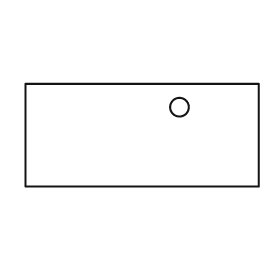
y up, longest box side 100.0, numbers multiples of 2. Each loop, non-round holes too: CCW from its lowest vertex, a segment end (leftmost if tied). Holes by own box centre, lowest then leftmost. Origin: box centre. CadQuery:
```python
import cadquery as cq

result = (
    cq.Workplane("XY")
    .moveTo(-50.0, -22.0)
    .lineTo(50.0, -22.0)
    .lineTo(50.0, 22.0)
    .lineTo(-50.0, 22.0)
    .close()
    .moveTo(16.0, 12.0)
    .circle(4.0)
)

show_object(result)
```